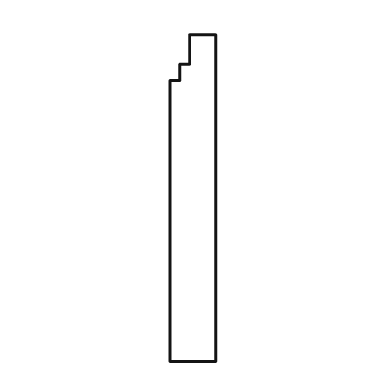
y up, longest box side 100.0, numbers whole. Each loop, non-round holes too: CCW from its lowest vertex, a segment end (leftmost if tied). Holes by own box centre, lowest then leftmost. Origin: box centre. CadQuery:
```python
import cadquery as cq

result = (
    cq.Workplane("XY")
    .moveTo(-7.0, -50.0)
    .lineTo(7.0, -50.0)
    .lineTo(7.0, 50.0)
    .lineTo(-1.0, 50.0)
    .lineTo(-1.0, 41.0)
    .lineTo(-4.0, 41.0)
    .lineTo(-4.0, 36.0)
    .lineTo(-7.0, 36.0)
    .close()
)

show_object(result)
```